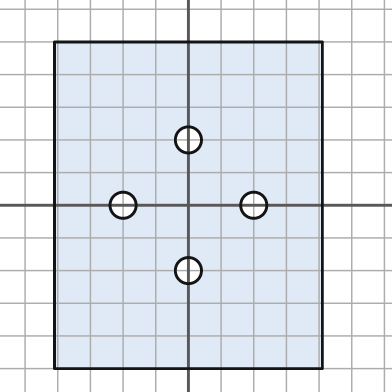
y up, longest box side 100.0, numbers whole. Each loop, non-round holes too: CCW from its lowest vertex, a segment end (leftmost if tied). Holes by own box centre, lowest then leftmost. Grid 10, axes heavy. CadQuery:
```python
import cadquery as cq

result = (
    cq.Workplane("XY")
    .moveTo(-41.0, -50.0)
    .lineTo(41.0, -50.0)
    .lineTo(41.0, 50.0)
    .lineTo(-41.0, 50.0)
    .close()
    .moveTo(0.0, -20.0)
    .circle(4.0)
    .moveTo(-20.0, 0.0)
    .circle(4.0)
    .moveTo(20.0, 0.0)
    .circle(4.0)
    .moveTo(0.0, 20.0)
    .circle(4.0)
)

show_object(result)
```